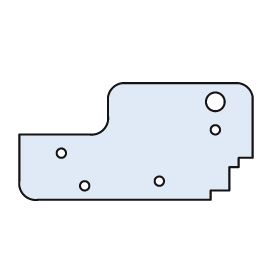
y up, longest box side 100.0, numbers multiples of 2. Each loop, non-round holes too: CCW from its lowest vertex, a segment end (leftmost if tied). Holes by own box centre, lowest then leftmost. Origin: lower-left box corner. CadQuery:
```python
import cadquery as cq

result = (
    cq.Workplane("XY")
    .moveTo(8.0, 0.0)
    .lineTo(82.0, 0.0)
    .lineTo(82.0, 4.0)
    .lineTo(90.0, 4.0)
    .lineTo(90.0, 14.0)
    .lineTo(94.0, 14.0)
    .lineTo(94.0, 18.0)
    .lineTo(100.0, 18.0)
    .lineTo(100.0, 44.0)
    .threePointArc((98.0, 48.0), (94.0, 50.0))
    .lineTo(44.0, 50.0)
    .threePointArc((40.0, 48.0), (38.0, 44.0))
    .lineTo(38.0, 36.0)
    .threePointArc((36.0, 30.0), (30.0, 28.0))
    .lineTo(0.0, 28.0)
    .lineTo(0.0, 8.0)
    .threePointArc((2.0, 2.0), (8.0, 0.0))
    .close()
    .moveTo(28.0, 6.0)
    .circle(2.0)
    .moveTo(60.0, 8.0)
    .circle(2.0)
    .moveTo(18.0, 20.0)
    .circle(2.0)
    .moveTo(84.0, 30.0)
    .circle(2.0)
    .moveTo(84.0, 42.0)
    .circle(4.0)
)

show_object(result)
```